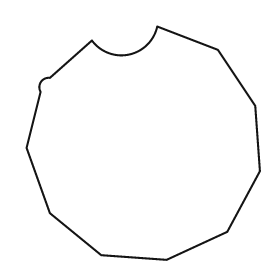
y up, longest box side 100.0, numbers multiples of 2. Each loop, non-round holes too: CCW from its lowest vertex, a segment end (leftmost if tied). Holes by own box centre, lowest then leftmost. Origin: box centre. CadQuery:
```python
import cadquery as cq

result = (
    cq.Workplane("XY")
    .moveTo(10.0, -50.0)
    .lineTo(36.0, -38.0)
    .lineTo(50.0, -12.0)
    .lineTo(48.0, 16.0)
    .lineTo(32.0, 40.0)
    .lineTo(6.0, 50.0)
    .threePointArc((-6.0, 38.0), (-22.0, 44.0))
    .lineTo(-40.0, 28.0)
    .threePointArc((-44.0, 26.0), (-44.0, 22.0))
    .lineTo(-50.0, -2.0)
    .lineTo(-40.0, -30.0)
    .lineTo(-18.0, -48.0)
    .close()
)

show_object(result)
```